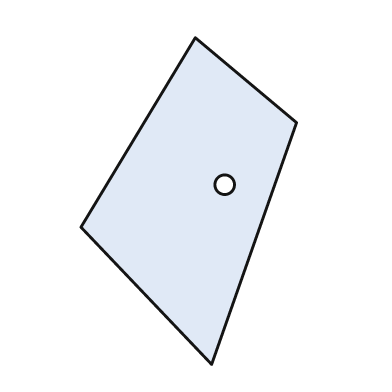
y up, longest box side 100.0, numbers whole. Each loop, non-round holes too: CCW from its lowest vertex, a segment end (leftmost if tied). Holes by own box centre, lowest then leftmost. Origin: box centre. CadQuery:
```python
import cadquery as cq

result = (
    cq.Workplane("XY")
    .moveTo(7.0, -50.0)
    .lineTo(33.0, 24.0)
    .lineTo(2.0, 50.0)
    .lineTo(-33.0, -8.0)
    .close()
    .moveTo(11.0, 5.0)
    .circle(3.0)
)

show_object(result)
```